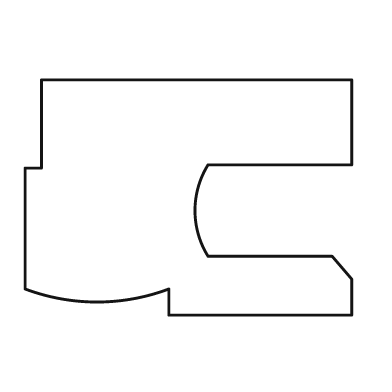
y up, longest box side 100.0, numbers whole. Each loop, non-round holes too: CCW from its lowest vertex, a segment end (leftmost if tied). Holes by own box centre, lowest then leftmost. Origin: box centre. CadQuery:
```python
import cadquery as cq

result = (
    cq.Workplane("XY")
    .moveTo(-6.0, -36.0)
    .lineTo(50.0, -36.0)
    .lineTo(50.0, -25.0)
    .lineTo(44.0, -18.0)
    .lineTo(6.0, -18.0)
    .threePointArc((2.0, -4.0), (6.0, 10.0))
    .lineTo(50.0, 10.0)
    .lineTo(50.0, 36.0)
    .lineTo(-45.0, 36.0)
    .lineTo(-45.0, 9.0)
    .lineTo(-50.0, 9.0)
    .lineTo(-50.0, -28.0)
    .threePointArc((-28.0, -32.0), (-6.0, -28.0))
    .close()
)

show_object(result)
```